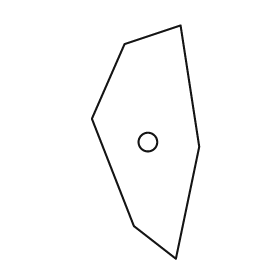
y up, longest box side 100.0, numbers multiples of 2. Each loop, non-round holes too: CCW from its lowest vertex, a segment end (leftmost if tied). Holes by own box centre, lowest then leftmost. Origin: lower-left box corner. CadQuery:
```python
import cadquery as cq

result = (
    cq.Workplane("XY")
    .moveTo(36.0, 0.0)
    .lineTo(46.0, 48.0)
    .lineTo(38.0, 100.0)
    .lineTo(14.0, 92.0)
    .lineTo(0.0, 60.0)
    .lineTo(18.0, 14.0)
    .close()
    .moveTo(24.0, 50.0)
    .circle(4.0)
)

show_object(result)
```